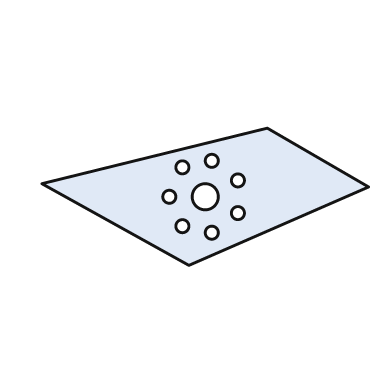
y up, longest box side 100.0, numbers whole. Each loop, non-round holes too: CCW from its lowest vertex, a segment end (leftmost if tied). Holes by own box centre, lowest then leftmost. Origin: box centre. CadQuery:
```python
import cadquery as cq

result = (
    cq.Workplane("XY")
    .moveTo(-5.0, -21.0)
    .lineTo(50.0, 3.0)
    .lineTo(19.0, 21.0)
    .lineTo(-50.0, 4.0)
    .close()
    .moveTo(2.0, -11.0)
    .circle(2.0)
    .moveTo(-7.0, -9.0)
    .circle(2.0)
    .moveTo(10.0, -5.0)
    .circle(2.0)
    .moveTo(-11.0, 0.0)
    .circle(2.0)
    .moveTo(0.0, 0.0)
    .circle(4.0)
    .moveTo(10.0, 5.0)
    .circle(2.0)
    .moveTo(-7.0, 9.0)
    .circle(2.0)
    .moveTo(2.0, 11.0)
    .circle(2.0)
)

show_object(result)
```